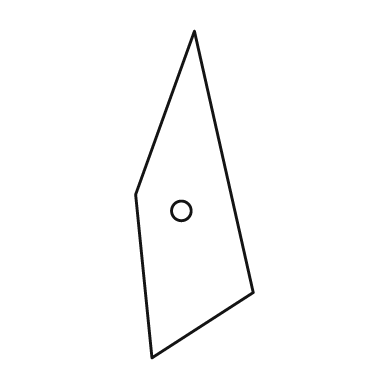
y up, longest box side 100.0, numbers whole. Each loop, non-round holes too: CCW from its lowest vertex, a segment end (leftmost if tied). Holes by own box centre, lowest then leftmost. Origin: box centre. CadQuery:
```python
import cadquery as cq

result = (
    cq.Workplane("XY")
    .moveTo(-13.0, -50.0)
    .lineTo(18.0, -30.0)
    .lineTo(0.0, 50.0)
    .lineTo(-18.0, 0.0)
    .close()
    .moveTo(-4.0, -5.0)
    .circle(3.0)
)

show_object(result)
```